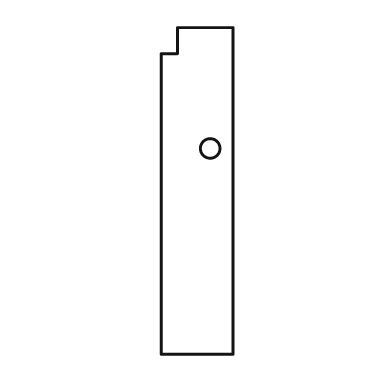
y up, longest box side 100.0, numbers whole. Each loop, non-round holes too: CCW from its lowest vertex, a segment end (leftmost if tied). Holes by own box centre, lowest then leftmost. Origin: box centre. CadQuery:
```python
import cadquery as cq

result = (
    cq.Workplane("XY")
    .moveTo(-11.0, -50.0)
    .lineTo(11.0, -50.0)
    .lineTo(11.0, 50.0)
    .lineTo(-6.0, 50.0)
    .lineTo(-6.0, 42.0)
    .lineTo(-11.0, 42.0)
    .close()
    .moveTo(4.0, 13.0)
    .circle(3.0)
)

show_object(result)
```